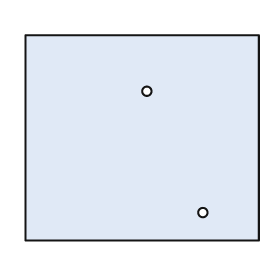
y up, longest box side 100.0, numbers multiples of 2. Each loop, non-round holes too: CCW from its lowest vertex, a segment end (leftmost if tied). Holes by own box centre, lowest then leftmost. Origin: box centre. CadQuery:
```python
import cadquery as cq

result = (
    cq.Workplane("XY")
    .moveTo(-50.0, -44.0)
    .lineTo(50.0, -44.0)
    .lineTo(50.0, 44.0)
    .lineTo(-50.0, 44.0)
    .close()
    .moveTo(26.0, -32.0)
    .circle(2.0)
    .moveTo(2.0, 20.0)
    .circle(2.0)
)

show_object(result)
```